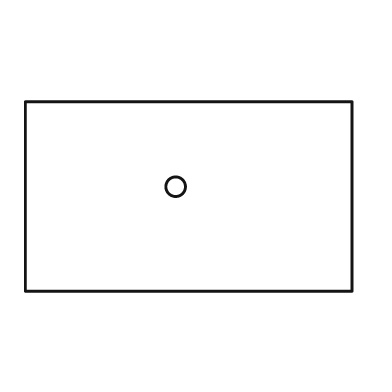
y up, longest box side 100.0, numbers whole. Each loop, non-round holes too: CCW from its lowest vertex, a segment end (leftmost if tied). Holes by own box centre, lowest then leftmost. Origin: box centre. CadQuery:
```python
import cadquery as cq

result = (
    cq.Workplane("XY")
    .moveTo(-50.0, -29.0)
    .lineTo(50.0, -29.0)
    .lineTo(50.0, 29.0)
    .lineTo(-50.0, 29.0)
    .close()
    .moveTo(-4.0, 3.0)
    .circle(3.0)
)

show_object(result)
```